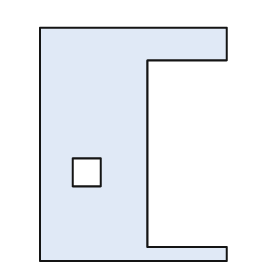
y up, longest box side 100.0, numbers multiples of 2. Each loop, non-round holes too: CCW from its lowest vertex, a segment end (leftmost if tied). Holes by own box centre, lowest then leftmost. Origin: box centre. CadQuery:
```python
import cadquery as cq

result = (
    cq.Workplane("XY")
    .moveTo(-40.0, -50.0)
    .lineTo(40.0, -50.0)
    .lineTo(40.0, -44.0)
    .lineTo(6.0, -44.0)
    .lineTo(6.0, 36.0)
    .lineTo(40.0, 36.0)
    .lineTo(40.0, 50.0)
    .lineTo(-40.0, 50.0)
    .close()
    .moveTo(-26.0, -18.0)
    .lineTo(-14.0, -18.0)
    .lineTo(-14.0, -6.0)
    .lineTo(-26.0, -6.0)
    .close()
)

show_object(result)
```